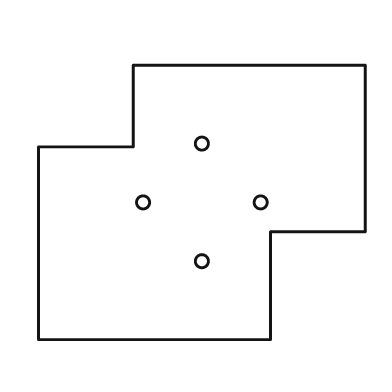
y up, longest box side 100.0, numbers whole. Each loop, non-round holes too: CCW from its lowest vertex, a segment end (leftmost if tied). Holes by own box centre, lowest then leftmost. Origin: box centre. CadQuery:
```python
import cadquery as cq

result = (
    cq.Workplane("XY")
    .moveTo(-50.0, -42.0)
    .lineTo(21.0, -42.0)
    .lineTo(21.0, -9.0)
    .lineTo(50.0, -9.0)
    .lineTo(50.0, 42.0)
    .lineTo(-21.0, 42.0)
    .lineTo(-21.0, 17.0)
    .lineTo(-50.0, 17.0)
    .close()
    .moveTo(0.0, -18.0)
    .circle(2.0)
    .moveTo(-18.0, 0.0)
    .circle(2.0)
    .moveTo(18.0, 0.0)
    .circle(2.0)
    .moveTo(0.0, 18.0)
    .circle(2.0)
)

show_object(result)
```